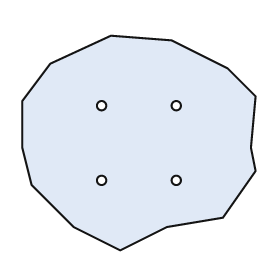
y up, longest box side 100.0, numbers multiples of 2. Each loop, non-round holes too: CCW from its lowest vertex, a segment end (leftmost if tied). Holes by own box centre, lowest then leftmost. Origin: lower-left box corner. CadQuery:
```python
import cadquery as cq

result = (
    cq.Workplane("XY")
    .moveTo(42.0, 0.0)
    .lineTo(62.0, 10.0)
    .lineTo(86.0, 14.0)
    .lineTo(100.0, 34.0)
    .lineTo(98.0, 44.0)
    .lineTo(100.0, 66.0)
    .lineTo(88.0, 78.0)
    .lineTo(64.0, 90.0)
    .lineTo(38.0, 92.0)
    .lineTo(12.0, 80.0)
    .lineTo(0.0, 64.0)
    .lineTo(0.0, 44.0)
    .lineTo(4.0, 28.0)
    .lineTo(22.0, 10.0)
    .close()
    .moveTo(34.0, 30.0)
    .circle(2.0)
    .moveTo(66.0, 30.0)
    .circle(2.0)
    .moveTo(34.0, 62.0)
    .circle(2.0)
    .moveTo(66.0, 62.0)
    .circle(2.0)
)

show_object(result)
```